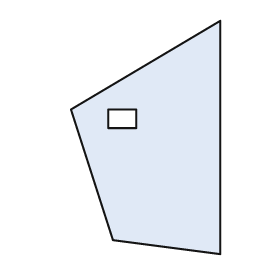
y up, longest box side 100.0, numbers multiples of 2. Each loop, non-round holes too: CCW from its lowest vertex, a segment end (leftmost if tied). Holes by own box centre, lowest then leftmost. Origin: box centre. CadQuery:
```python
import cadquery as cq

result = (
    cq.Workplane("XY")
    .moveTo(32.0, -50.0)
    .lineTo(32.0, 50.0)
    .lineTo(-32.0, 12.0)
    .lineTo(-14.0, -44.0)
    .close()
    .moveTo(-16.0, 4.0)
    .lineTo(-4.0, 4.0)
    .lineTo(-4.0, 12.0)
    .lineTo(-16.0, 12.0)
    .close()
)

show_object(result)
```